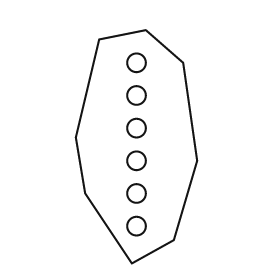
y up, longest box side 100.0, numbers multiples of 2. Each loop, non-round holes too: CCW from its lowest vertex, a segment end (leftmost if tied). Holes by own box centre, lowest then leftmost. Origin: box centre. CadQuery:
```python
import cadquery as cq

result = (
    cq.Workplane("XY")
    .moveTo(-2.0, -50.0)
    .lineTo(16.0, -40.0)
    .lineTo(26.0, -6.0)
    .lineTo(20.0, 36.0)
    .lineTo(4.0, 50.0)
    .lineTo(-16.0, 46.0)
    .lineTo(-26.0, 4.0)
    .lineTo(-22.0, -20.0)
    .close()
    .moveTo(0.0, -34.0)
    .circle(4.0)
    .moveTo(0.0, -20.0)
    .circle(4.0)
    .moveTo(0.0, -6.0)
    .circle(4.0)
    .moveTo(0.0, 8.0)
    .circle(4.0)
    .moveTo(0.0, 22.0)
    .circle(4.0)
    .moveTo(0.0, 36.0)
    .circle(4.0)
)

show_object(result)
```